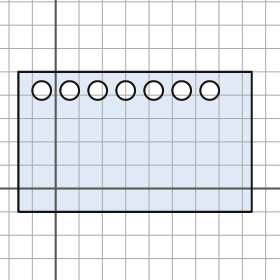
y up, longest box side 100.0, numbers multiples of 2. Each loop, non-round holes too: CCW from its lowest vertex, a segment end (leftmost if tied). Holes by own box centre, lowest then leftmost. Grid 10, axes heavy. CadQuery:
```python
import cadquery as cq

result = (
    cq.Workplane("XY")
    .moveTo(-16.0, -10.0)
    .lineTo(84.0, -10.0)
    .lineTo(84.0, 50.0)
    .lineTo(-16.0, 50.0)
    .close()
    .moveTo(-6.0, 42.0)
    .circle(4.0)
    .moveTo(6.0, 42.0)
    .circle(4.0)
    .moveTo(18.0, 42.0)
    .circle(4.0)
    .moveTo(30.0, 42.0)
    .circle(4.0)
    .moveTo(42.0, 42.0)
    .circle(4.0)
    .moveTo(54.0, 42.0)
    .circle(4.0)
    .moveTo(66.0, 42.0)
    .circle(4.0)
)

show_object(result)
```